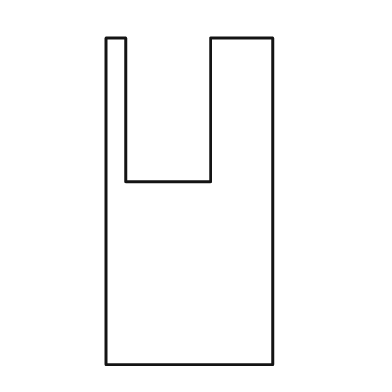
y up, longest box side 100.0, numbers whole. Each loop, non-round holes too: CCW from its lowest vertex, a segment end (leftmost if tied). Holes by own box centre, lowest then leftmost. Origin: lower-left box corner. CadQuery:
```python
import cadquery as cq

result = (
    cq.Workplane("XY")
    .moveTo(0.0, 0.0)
    .lineTo(51.0, 0.0)
    .lineTo(51.0, 100.0)
    .lineTo(32.0, 100.0)
    .lineTo(32.0, 56.0)
    .lineTo(6.0, 56.0)
    .lineTo(6.0, 100.0)
    .lineTo(0.0, 100.0)
    .close()
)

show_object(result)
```